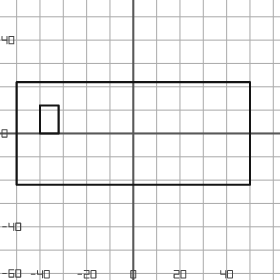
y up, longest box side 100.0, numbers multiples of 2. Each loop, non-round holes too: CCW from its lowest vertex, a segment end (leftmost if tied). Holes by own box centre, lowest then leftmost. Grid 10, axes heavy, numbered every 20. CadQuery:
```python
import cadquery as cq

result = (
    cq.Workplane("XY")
    .moveTo(-50.0, -22.0)
    .lineTo(50.0, -22.0)
    .lineTo(50.0, 22.0)
    .lineTo(-50.0, 22.0)
    .close()
    .moveTo(-40.0, 0.0)
    .lineTo(-32.0, 0.0)
    .lineTo(-32.0, 12.0)
    .lineTo(-40.0, 12.0)
    .close()
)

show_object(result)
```